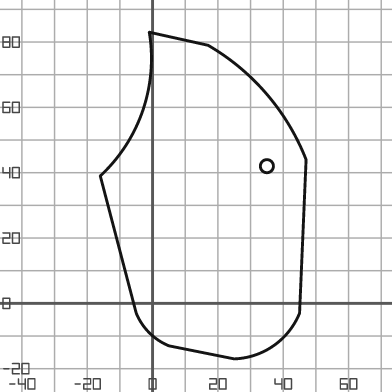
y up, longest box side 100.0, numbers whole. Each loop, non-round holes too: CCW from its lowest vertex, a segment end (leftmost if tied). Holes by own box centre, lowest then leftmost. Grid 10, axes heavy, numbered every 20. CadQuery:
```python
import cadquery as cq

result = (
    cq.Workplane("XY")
    .moveTo(25.0, -17.0)
    .threePointArc((37.0, -13.0), (45.0, -3.0))
    .lineTo(47.0, 44.0)
    .threePointArc((35.0, 64.0), (17.0, 79.0))
    .lineTo(-1.0, 83.0)
    .threePointArc((-3.0, 59.0), (-16.0, 39.0))
    .lineTo(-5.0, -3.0)
    .threePointArc((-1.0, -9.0), (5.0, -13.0))
    .close()
    .moveTo(35.0, 42.0)
    .circle(2.0)
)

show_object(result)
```